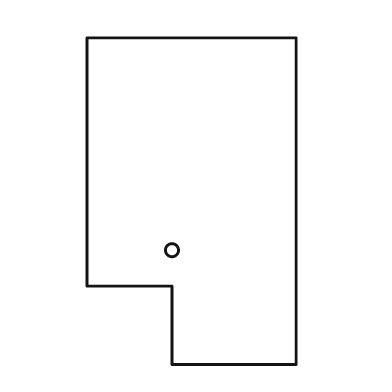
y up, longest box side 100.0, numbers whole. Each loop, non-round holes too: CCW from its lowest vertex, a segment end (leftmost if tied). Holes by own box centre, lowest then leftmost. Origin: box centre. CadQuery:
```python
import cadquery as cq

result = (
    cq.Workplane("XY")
    .moveTo(-6.0, -50.0)
    .lineTo(32.0, -50.0)
    .lineTo(32.0, 50.0)
    .lineTo(-32.0, 50.0)
    .lineTo(-32.0, -26.0)
    .lineTo(-6.0, -26.0)
    .close()
    .moveTo(-6.0, -15.0)
    .circle(2.0)
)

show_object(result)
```